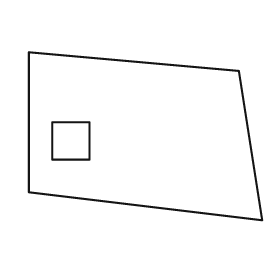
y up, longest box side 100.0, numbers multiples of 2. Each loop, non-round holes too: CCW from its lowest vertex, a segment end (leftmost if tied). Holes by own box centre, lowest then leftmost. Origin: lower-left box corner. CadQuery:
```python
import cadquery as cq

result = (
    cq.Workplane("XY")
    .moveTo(100.0, 0.0)
    .lineTo(90.0, 64.0)
    .lineTo(0.0, 72.0)
    .lineTo(0.0, 12.0)
    .close()
    .moveTo(10.0, 26.0)
    .lineTo(26.0, 26.0)
    .lineTo(26.0, 42.0)
    .lineTo(10.0, 42.0)
    .close()
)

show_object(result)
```